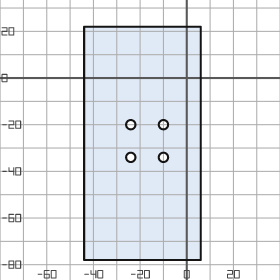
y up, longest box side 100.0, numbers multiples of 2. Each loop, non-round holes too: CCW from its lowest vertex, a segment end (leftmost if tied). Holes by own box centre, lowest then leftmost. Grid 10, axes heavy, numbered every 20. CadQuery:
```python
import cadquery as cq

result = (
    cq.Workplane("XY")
    .moveTo(-44.0, -78.0)
    .lineTo(6.0, -78.0)
    .lineTo(6.0, 22.0)
    .lineTo(-44.0, 22.0)
    .close()
    .moveTo(-24.0, -34.0)
    .circle(2.0)
    .moveTo(-10.0, -34.0)
    .circle(2.0)
    .moveTo(-24.0, -20.0)
    .circle(2.0)
    .moveTo(-10.0, -20.0)
    .circle(2.0)
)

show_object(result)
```